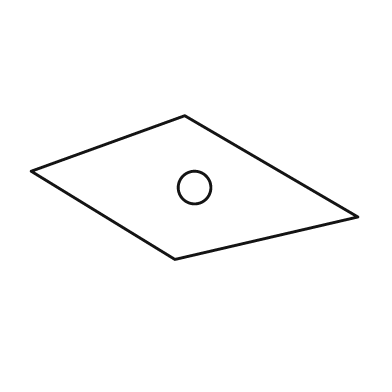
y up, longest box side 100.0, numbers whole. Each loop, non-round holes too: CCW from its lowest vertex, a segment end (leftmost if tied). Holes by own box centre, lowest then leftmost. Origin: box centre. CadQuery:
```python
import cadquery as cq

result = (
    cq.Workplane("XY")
    .moveTo(-6.0, -22.0)
    .lineTo(50.0, -9.0)
    .lineTo(-3.0, 22.0)
    .lineTo(-50.0, 5.0)
    .close()
    .moveTo(0.0, 0.0)
    .circle(5.0)
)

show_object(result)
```